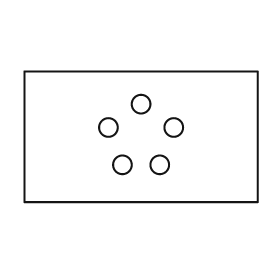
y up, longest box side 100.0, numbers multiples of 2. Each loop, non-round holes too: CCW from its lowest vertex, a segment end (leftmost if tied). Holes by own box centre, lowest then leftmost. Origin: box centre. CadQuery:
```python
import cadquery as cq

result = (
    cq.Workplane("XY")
    .moveTo(-50.0, -28.0)
    .lineTo(50.0, -28.0)
    .lineTo(50.0, 28.0)
    .lineTo(-50.0, 28.0)
    .close()
    .moveTo(-8.0, -12.0)
    .circle(4.0)
    .moveTo(8.0, -12.0)
    .circle(4.0)
    .moveTo(-14.0, 4.0)
    .circle(4.0)
    .moveTo(14.0, 4.0)
    .circle(4.0)
    .moveTo(0.0, 14.0)
    .circle(4.0)
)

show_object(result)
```